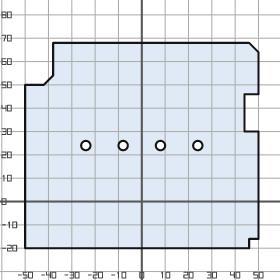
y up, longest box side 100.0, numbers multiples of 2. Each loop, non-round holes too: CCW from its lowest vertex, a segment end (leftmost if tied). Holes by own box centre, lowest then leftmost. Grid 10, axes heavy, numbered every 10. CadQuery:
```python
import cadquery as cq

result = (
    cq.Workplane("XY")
    .moveTo(-50.0, -20.0)
    .lineTo(46.0, -20.0)
    .lineTo(46.0, -16.0)
    .lineTo(50.0, -16.0)
    .lineTo(50.0, 30.0)
    .lineTo(44.0, 30.0)
    .lineTo(44.0, 46.0)
    .lineTo(50.0, 46.0)
    .lineTo(50.0, 64.0)
    .lineTo(46.0, 68.0)
    .lineTo(-38.0, 68.0)
    .lineTo(-38.0, 54.0)
    .lineTo(-42.0, 50.0)
    .lineTo(-50.0, 50.0)
    .close()
    .moveTo(-24.0, 24.0)
    .circle(2.0)
    .moveTo(-8.0, 24.0)
    .circle(2.0)
    .moveTo(8.0, 24.0)
    .circle(2.0)
    .moveTo(24.0, 24.0)
    .circle(2.0)
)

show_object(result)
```